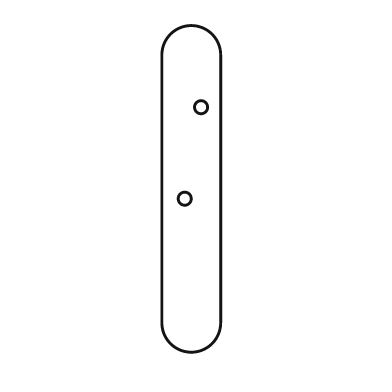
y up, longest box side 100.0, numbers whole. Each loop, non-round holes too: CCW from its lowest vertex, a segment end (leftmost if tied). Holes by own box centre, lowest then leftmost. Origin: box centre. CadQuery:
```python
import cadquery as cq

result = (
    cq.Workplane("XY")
    .moveTo(-9.0, -41.0)
    .threePointArc((0.0, -50.0), (9.0, -41.0))
    .lineTo(9.0, 41.0)
    .threePointArc((0.0, 50.0), (-9.0, 41.0))
    .close()
    .moveTo(-2.0, -3.0)
    .circle(2.0)
    .moveTo(3.0, 25.0)
    .circle(2.0)
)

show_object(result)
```